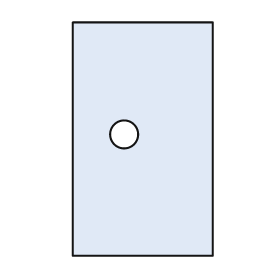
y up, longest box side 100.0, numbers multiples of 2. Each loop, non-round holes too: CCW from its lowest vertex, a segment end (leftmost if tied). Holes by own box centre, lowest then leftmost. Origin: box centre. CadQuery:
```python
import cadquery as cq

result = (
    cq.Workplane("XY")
    .moveTo(-30.0, -50.0)
    .lineTo(30.0, -50.0)
    .lineTo(30.0, 50.0)
    .lineTo(-30.0, 50.0)
    .close()
    .moveTo(-8.0, 2.0)
    .circle(6.0)
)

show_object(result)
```